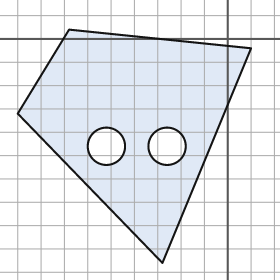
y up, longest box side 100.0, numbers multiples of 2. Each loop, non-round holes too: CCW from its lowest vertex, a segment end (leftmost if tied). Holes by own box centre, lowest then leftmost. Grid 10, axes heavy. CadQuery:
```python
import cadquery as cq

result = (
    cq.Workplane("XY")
    .moveTo(-28.0, -96.0)
    .lineTo(10.0, -4.0)
    .lineTo(-68.0, 4.0)
    .lineTo(-90.0, -32.0)
    .close()
    .moveTo(-52.0, -46.0)
    .circle(8.0)
    .moveTo(-26.0, -46.0)
    .circle(8.0)
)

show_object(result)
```